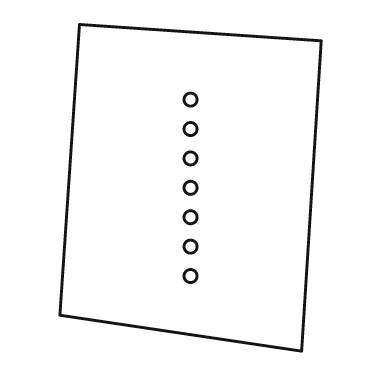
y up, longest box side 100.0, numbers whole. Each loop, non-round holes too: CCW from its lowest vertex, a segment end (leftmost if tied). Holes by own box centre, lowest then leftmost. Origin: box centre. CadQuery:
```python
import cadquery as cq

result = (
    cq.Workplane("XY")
    .moveTo(34.0, -50.0)
    .lineTo(40.0, 45.0)
    .lineTo(-34.0, 50.0)
    .lineTo(-40.0, -39.0)
    .close()
    .moveTo(0.0, -27.0)
    .circle(2.0)
    .moveTo(0.0, -18.0)
    .circle(2.0)
    .moveTo(0.0, -9.0)
    .circle(2.0)
    .moveTo(0.0, 0.0)
    .circle(2.0)
    .moveTo(0.0, 9.0)
    .circle(2.0)
    .moveTo(0.0, 18.0)
    .circle(2.0)
    .moveTo(0.0, 27.0)
    .circle(2.0)
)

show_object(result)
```